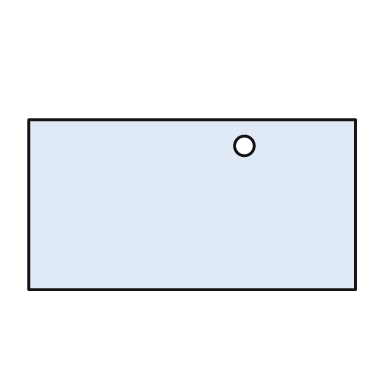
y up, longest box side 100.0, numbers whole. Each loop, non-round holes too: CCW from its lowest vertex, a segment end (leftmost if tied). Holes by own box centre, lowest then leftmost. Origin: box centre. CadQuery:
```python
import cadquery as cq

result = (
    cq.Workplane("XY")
    .moveTo(-50.0, -26.0)
    .lineTo(50.0, -26.0)
    .lineTo(50.0, 26.0)
    .lineTo(-50.0, 26.0)
    .close()
    .moveTo(16.0, 18.0)
    .circle(3.0)
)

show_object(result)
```